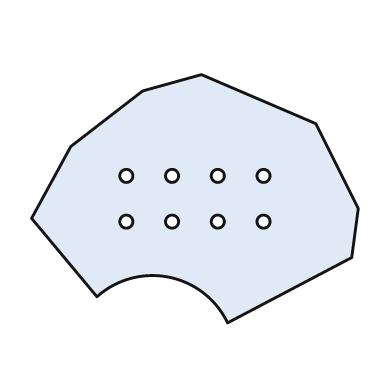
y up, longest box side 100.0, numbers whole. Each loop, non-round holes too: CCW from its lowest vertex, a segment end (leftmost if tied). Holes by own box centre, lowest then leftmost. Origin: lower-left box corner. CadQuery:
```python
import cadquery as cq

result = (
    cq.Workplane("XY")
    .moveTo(60.0, 0.0)
    .lineTo(98.0, 20.0)
    .lineTo(100.0, 35.0)
    .lineTo(87.0, 61.0)
    .lineTo(52.0, 76.0)
    .lineTo(34.0, 71.0)
    .lineTo(12.0, 54.0)
    .lineTo(0.0, 32.0)
    .lineTo(20.0, 8.0)
    .threePointArc((42.0, 14.0), (60.0, 0.0))
    .close()
    .moveTo(29.0, 31.0)
    .circle(2.0)
    .moveTo(43.0, 31.0)
    .circle(2.0)
    .moveTo(57.0, 31.0)
    .circle(2.0)
    .moveTo(71.0, 31.0)
    .circle(2.0)
    .moveTo(29.0, 45.0)
    .circle(2.0)
    .moveTo(43.0, 45.0)
    .circle(2.0)
    .moveTo(57.0, 45.0)
    .circle(2.0)
    .moveTo(71.0, 45.0)
    .circle(2.0)
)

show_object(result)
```